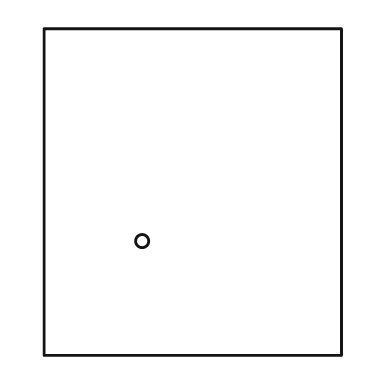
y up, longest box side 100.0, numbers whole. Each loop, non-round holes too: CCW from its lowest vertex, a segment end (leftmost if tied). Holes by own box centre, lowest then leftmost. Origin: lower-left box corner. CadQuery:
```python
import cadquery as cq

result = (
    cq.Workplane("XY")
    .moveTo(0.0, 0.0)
    .lineTo(91.0, 0.0)
    .lineTo(91.0, 100.0)
    .lineTo(0.0, 100.0)
    .close()
    .moveTo(30.0, 35.0)
    .circle(2.0)
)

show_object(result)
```